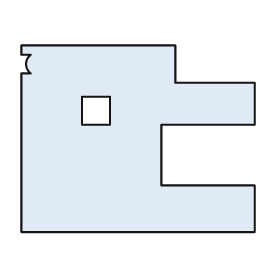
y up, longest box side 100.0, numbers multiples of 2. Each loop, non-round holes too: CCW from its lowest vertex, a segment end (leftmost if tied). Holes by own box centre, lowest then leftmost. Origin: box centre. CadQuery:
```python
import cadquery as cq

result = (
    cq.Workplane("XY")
    .moveTo(-50.0, -40.0)
    .lineTo(50.0, -40.0)
    .lineTo(50.0, -20.0)
    .lineTo(10.0, -20.0)
    .lineTo(10.0, 6.0)
    .lineTo(50.0, 6.0)
    .lineTo(50.0, 24.0)
    .lineTo(16.0, 24.0)
    .lineTo(16.0, 40.0)
    .lineTo(-50.0, 40.0)
    .lineTo(-50.0, 36.0)
    .lineTo(-46.0, 36.0)
    .threePointArc((-48.0, 32.0), (-46.0, 28.0))
    .lineTo(-50.0, 28.0)
    .close()
    .moveTo(-24.0, 6.0)
    .lineTo(-12.0, 6.0)
    .lineTo(-12.0, 18.0)
    .lineTo(-24.0, 18.0)
    .close()
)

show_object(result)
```